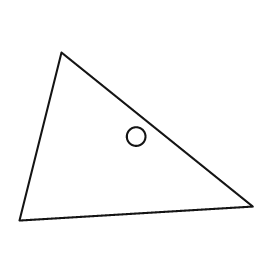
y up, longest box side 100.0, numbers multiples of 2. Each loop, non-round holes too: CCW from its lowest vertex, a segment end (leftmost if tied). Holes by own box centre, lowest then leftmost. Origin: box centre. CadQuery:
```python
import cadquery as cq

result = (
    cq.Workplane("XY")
    .moveTo(-50.0, -36.0)
    .lineTo(50.0, -30.0)
    .lineTo(-32.0, 36.0)
    .close()
    .moveTo(0.0, 0.0)
    .circle(4.0)
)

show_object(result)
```